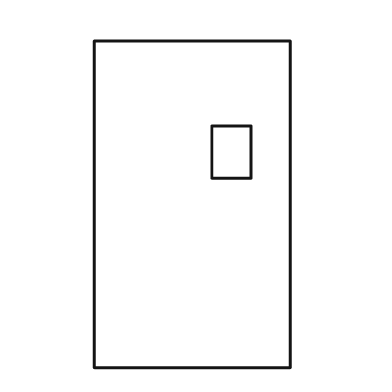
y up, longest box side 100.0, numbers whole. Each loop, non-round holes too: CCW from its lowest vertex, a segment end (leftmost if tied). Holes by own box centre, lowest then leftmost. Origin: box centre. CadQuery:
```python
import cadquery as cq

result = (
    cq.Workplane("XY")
    .moveTo(-30.0, -50.0)
    .lineTo(30.0, -50.0)
    .lineTo(30.0, 50.0)
    .lineTo(-30.0, 50.0)
    .close()
    .moveTo(6.0, 8.0)
    .lineTo(18.0, 8.0)
    .lineTo(18.0, 24.0)
    .lineTo(6.0, 24.0)
    .close()
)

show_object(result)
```